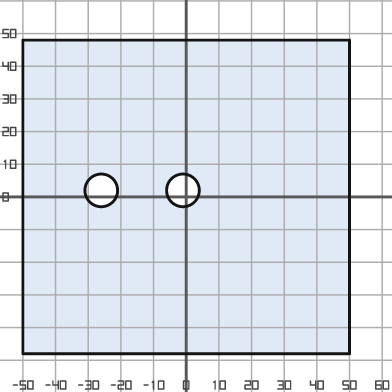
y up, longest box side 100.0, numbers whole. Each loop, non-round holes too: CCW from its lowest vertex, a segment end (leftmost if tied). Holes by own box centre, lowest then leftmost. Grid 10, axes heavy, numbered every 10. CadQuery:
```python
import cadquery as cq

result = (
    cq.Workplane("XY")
    .moveTo(-50.0, -48.0)
    .lineTo(50.0, -48.0)
    .lineTo(50.0, 48.0)
    .lineTo(-50.0, 48.0)
    .close()
    .moveTo(-26.0, 2.0)
    .circle(5.0)
    .moveTo(-1.0, 2.0)
    .circle(5.0)
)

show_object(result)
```